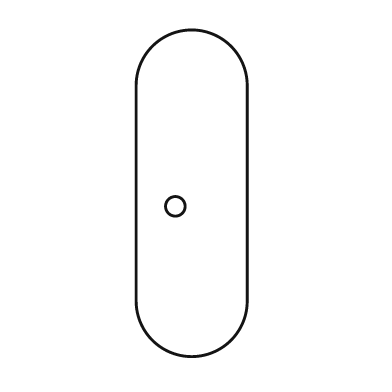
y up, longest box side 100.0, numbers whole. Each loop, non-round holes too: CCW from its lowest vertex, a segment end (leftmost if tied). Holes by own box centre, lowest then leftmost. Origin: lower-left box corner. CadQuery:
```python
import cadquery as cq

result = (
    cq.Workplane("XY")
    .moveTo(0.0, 17.0)
    .threePointArc((17.0, 0.0), (34.0, 17.0))
    .lineTo(34.0, 83.0)
    .threePointArc((17.0, 100.0), (0.0, 83.0))
    .close()
    .moveTo(12.0, 46.0)
    .circle(3.0)
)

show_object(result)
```